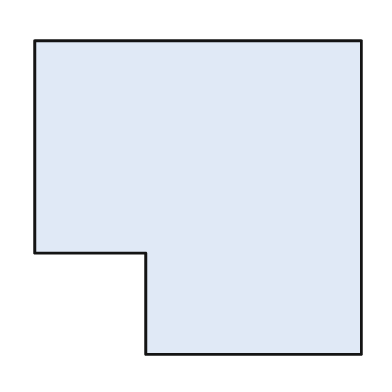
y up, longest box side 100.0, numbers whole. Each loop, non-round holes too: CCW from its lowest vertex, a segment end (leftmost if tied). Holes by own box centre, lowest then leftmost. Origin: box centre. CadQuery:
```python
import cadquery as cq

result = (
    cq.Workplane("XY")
    .moveTo(-16.0, -48.0)
    .lineTo(50.0, -48.0)
    .lineTo(50.0, 48.0)
    .lineTo(-50.0, 48.0)
    .lineTo(-50.0, -17.0)
    .lineTo(-16.0, -17.0)
    .close()
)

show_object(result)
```